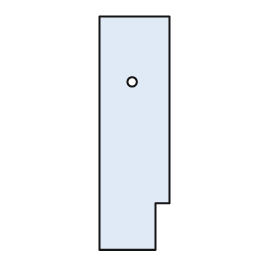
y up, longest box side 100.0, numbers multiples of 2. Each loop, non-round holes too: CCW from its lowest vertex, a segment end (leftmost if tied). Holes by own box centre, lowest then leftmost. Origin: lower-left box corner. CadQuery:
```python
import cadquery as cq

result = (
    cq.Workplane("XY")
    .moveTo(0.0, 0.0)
    .lineTo(24.0, 0.0)
    .lineTo(24.0, 20.0)
    .lineTo(30.0, 20.0)
    .lineTo(30.0, 100.0)
    .lineTo(0.0, 100.0)
    .close()
    .moveTo(14.0, 72.0)
    .circle(2.0)
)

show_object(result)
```